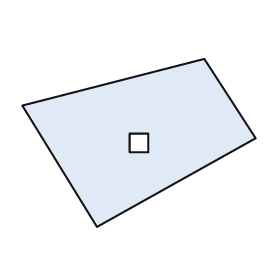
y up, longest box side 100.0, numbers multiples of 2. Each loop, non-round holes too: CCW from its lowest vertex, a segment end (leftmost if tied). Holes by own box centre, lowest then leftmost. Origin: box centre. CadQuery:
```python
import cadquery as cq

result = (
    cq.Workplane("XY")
    .moveTo(-18.0, -36.0)
    .lineTo(50.0, 2.0)
    .lineTo(28.0, 36.0)
    .lineTo(-50.0, 16.0)
    .close()
    .moveTo(-4.0, -4.0)
    .lineTo(4.0, -4.0)
    .lineTo(4.0, 4.0)
    .lineTo(-4.0, 4.0)
    .close()
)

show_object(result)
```